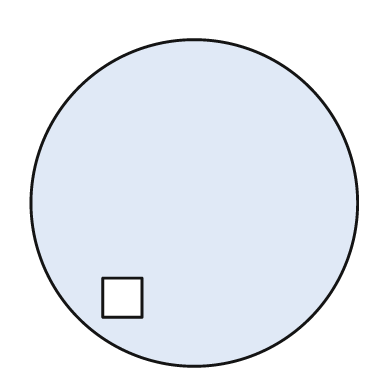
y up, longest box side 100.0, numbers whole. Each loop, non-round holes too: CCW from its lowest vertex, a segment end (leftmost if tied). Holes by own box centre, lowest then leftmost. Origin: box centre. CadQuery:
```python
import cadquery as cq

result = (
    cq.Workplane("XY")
    .moveTo(0.0, 0.0)
    .circle(50.0)
    .moveTo(-28.0, -35.0)
    .lineTo(-16.0, -35.0)
    .lineTo(-16.0, -23.0)
    .lineTo(-28.0, -23.0)
    .close()
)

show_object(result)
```